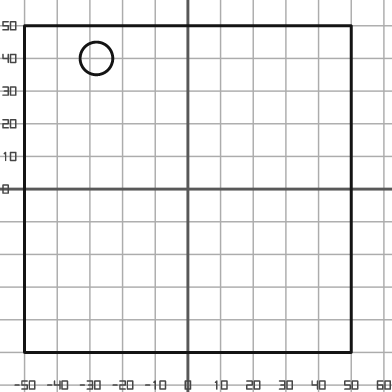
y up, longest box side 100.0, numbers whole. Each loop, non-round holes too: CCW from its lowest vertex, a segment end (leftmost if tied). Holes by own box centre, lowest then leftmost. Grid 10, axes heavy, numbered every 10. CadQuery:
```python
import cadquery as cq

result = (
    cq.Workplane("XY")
    .moveTo(-50.0, -50.0)
    .lineTo(50.0, -50.0)
    .lineTo(50.0, 50.0)
    .lineTo(-50.0, 50.0)
    .close()
    .moveTo(-28.0, 40.0)
    .circle(5.0)
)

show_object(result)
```